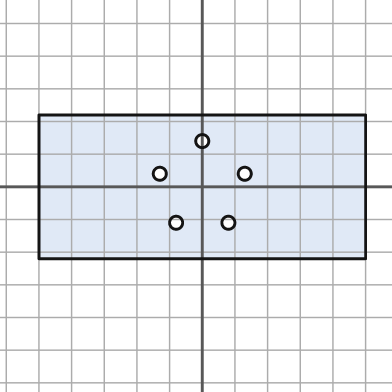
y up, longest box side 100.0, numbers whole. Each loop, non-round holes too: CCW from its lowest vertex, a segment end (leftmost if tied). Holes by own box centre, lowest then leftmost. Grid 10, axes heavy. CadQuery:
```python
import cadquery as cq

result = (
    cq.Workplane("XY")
    .moveTo(-50.0, -22.0)
    .lineTo(50.0, -22.0)
    .lineTo(50.0, 22.0)
    .lineTo(-50.0, 22.0)
    .close()
    .moveTo(-8.0, -11.0)
    .circle(2.0)
    .moveTo(8.0, -11.0)
    .circle(2.0)
    .moveTo(-13.0, 4.0)
    .circle(2.0)
    .moveTo(13.0, 4.0)
    .circle(2.0)
    .moveTo(0.0, 14.0)
    .circle(2.0)
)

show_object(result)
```